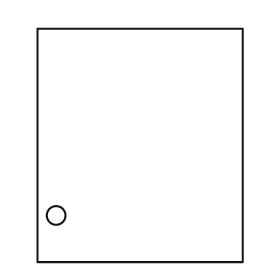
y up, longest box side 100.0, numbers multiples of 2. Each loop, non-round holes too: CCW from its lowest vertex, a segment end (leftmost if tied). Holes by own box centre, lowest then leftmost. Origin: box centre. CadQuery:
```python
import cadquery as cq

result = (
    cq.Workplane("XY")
    .moveTo(-44.0, -50.0)
    .lineTo(44.0, -50.0)
    .lineTo(44.0, 50.0)
    .lineTo(-44.0, 50.0)
    .close()
    .moveTo(-36.0, -30.0)
    .circle(4.0)
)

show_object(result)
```